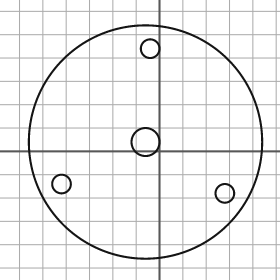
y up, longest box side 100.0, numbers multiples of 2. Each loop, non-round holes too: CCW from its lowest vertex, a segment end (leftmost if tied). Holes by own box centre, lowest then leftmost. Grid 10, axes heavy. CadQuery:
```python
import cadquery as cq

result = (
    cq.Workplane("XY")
    .moveTo(-6.0, 4.0)
    .circle(50.0)
    .moveTo(28.0, -18.0)
    .circle(4.0)
    .moveTo(-42.0, -14.0)
    .circle(4.0)
    .moveTo(-6.0, 4.0)
    .circle(6.0)
    .moveTo(-4.0, 44.0)
    .circle(4.0)
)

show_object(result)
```